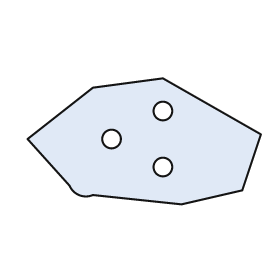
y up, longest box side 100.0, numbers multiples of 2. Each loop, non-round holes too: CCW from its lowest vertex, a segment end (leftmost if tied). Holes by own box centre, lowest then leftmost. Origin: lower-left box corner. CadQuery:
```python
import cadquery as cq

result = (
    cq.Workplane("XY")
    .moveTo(66.0, 0.0)
    .lineTo(92.0, 6.0)
    .lineTo(100.0, 30.0)
    .lineTo(58.0, 54.0)
    .lineTo(28.0, 50.0)
    .lineTo(0.0, 28.0)
    .lineTo(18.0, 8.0)
    .threePointArc((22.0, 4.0), (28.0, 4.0))
    .close()
    .moveTo(58.0, 16.0)
    .circle(4.0)
    .moveTo(36.0, 28.0)
    .circle(4.0)
    .moveTo(58.0, 40.0)
    .circle(4.0)
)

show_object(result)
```